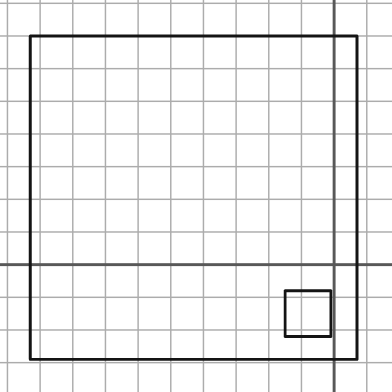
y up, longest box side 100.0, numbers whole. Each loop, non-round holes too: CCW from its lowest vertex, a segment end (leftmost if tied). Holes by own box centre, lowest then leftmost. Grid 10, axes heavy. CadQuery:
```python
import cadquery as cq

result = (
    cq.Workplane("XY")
    .moveTo(-93.0, -29.0)
    .lineTo(7.0, -29.0)
    .lineTo(7.0, 70.0)
    .lineTo(-93.0, 70.0)
    .close()
    .moveTo(-15.0, -22.0)
    .lineTo(-1.0, -22.0)
    .lineTo(-1.0, -8.0)
    .lineTo(-15.0, -8.0)
    .close()
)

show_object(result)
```